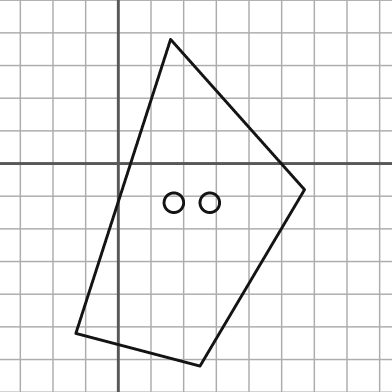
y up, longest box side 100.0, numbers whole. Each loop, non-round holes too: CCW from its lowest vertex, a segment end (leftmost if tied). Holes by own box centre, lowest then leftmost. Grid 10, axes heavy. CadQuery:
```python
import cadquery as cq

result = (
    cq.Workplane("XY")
    .moveTo(25.0, -62.0)
    .lineTo(57.0, -8.0)
    .lineTo(16.0, 38.0)
    .lineTo(-13.0, -52.0)
    .close()
    .moveTo(17.0, -12.0)
    .circle(3.0)
    .moveTo(28.0, -12.0)
    .circle(3.0)
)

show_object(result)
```